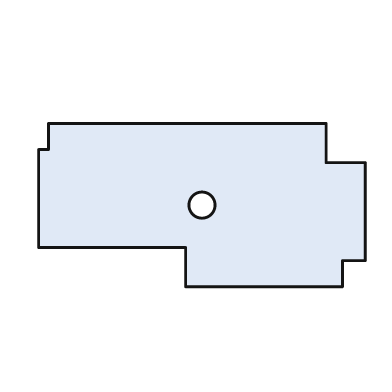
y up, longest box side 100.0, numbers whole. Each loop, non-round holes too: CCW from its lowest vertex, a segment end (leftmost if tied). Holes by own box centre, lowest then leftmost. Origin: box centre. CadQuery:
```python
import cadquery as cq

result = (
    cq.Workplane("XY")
    .moveTo(-5.0, -25.0)
    .lineTo(43.0, -25.0)
    .lineTo(43.0, -17.0)
    .lineTo(50.0, -17.0)
    .lineTo(50.0, 13.0)
    .lineTo(38.0, 13.0)
    .lineTo(38.0, 25.0)
    .lineTo(-47.0, 25.0)
    .lineTo(-47.0, 17.0)
    .lineTo(-50.0, 17.0)
    .lineTo(-50.0, -13.0)
    .lineTo(-5.0, -13.0)
    .close()
    .moveTo(0.0, 0.0)
    .circle(4.0)
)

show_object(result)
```